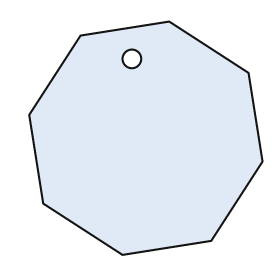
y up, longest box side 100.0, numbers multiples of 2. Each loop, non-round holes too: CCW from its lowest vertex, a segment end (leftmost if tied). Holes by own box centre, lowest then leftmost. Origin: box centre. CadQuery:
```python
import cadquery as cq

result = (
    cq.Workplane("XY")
    .moveTo(-10.0, -50.0)
    .lineTo(28.0, -44.0)
    .lineTo(50.0, -10.0)
    .lineTo(44.0, 28.0)
    .lineTo(10.0, 50.0)
    .lineTo(-28.0, 44.0)
    .lineTo(-50.0, 10.0)
    .lineTo(-44.0, -28.0)
    .close()
    .moveTo(-6.0, 34.0)
    .circle(4.0)
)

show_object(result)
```